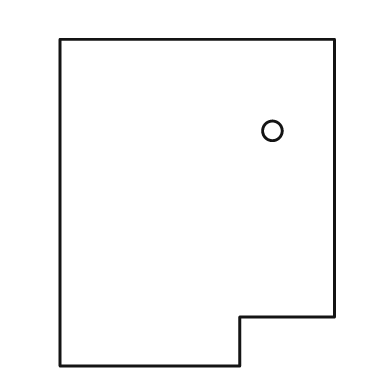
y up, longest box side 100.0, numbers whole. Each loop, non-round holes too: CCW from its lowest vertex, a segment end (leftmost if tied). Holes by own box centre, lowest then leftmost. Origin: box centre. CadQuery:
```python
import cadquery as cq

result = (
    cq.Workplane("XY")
    .moveTo(-42.0, -50.0)
    .lineTo(13.0, -50.0)
    .lineTo(13.0, -35.0)
    .lineTo(42.0, -35.0)
    .lineTo(42.0, 50.0)
    .lineTo(-42.0, 50.0)
    .close()
    .moveTo(23.0, 22.0)
    .circle(3.0)
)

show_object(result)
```